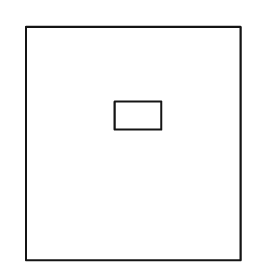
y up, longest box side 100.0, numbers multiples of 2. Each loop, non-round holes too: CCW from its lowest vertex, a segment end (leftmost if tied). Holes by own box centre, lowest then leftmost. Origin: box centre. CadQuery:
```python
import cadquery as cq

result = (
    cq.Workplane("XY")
    .moveTo(-46.0, -50.0)
    .lineTo(46.0, -50.0)
    .lineTo(46.0, 50.0)
    .lineTo(-46.0, 50.0)
    .close()
    .moveTo(-8.0, 6.0)
    .lineTo(12.0, 6.0)
    .lineTo(12.0, 18.0)
    .lineTo(-8.0, 18.0)
    .close()
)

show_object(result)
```